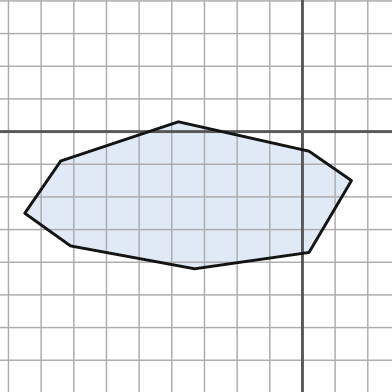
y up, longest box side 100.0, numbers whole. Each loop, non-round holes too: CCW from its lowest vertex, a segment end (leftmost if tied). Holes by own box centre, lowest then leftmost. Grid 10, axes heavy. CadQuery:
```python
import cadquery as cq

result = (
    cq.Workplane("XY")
    .moveTo(-33.0, -42.0)
    .lineTo(2.0, -37.0)
    .lineTo(15.0, -15.0)
    .lineTo(2.0, -6.0)
    .lineTo(-38.0, 3.0)
    .lineTo(-74.0, -9.0)
    .lineTo(-85.0, -25.0)
    .lineTo(-71.0, -35.0)
    .close()
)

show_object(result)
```